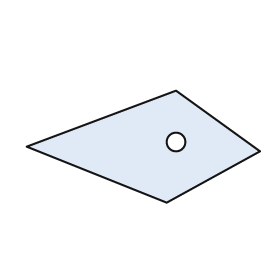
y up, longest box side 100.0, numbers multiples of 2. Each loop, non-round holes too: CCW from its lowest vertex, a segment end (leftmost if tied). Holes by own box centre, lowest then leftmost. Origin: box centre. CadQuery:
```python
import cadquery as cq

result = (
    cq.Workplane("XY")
    .moveTo(10.0, -24.0)
    .lineTo(50.0, -2.0)
    .lineTo(14.0, 24.0)
    .lineTo(-50.0, 0.0)
    .close()
    .moveTo(14.0, 2.0)
    .circle(4.0)
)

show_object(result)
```